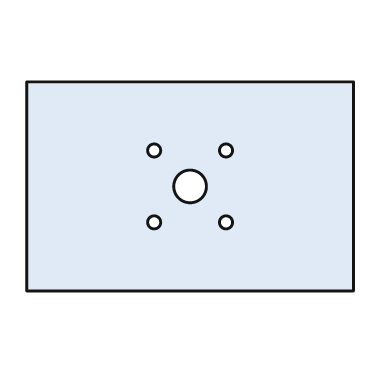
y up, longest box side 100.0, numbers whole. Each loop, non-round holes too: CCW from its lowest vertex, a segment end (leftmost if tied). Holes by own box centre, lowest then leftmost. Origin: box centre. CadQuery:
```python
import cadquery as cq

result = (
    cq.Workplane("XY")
    .moveTo(-50.0, -32.0)
    .lineTo(50.0, -32.0)
    .lineTo(50.0, 32.0)
    .lineTo(-50.0, 32.0)
    .close()
    .moveTo(-11.0, -11.0)
    .circle(2.0)
    .moveTo(11.0, -11.0)
    .circle(2.0)
    .moveTo(0.0, 0.0)
    .circle(5.0)
    .moveTo(-11.0, 11.0)
    .circle(2.0)
    .moveTo(11.0, 11.0)
    .circle(2.0)
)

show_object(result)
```